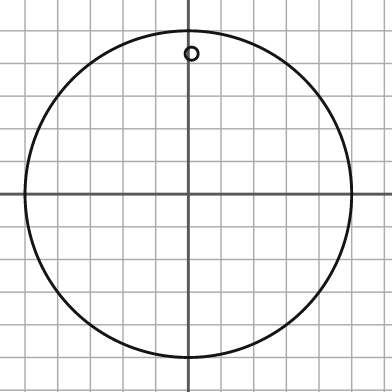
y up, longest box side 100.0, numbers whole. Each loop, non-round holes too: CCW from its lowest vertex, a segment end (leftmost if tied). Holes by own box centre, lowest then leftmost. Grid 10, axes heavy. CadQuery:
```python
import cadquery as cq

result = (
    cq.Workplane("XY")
    .moveTo(0.0, 0.0)
    .circle(50.0)
    .moveTo(1.0, 43.0)
    .circle(2.0)
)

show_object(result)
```